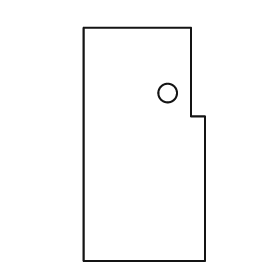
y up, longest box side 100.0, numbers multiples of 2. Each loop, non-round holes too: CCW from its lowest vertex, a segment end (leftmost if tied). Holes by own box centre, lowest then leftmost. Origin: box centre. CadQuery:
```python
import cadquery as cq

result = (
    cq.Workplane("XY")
    .moveTo(-26.0, -50.0)
    .lineTo(26.0, -50.0)
    .lineTo(26.0, 12.0)
    .lineTo(20.0, 12.0)
    .lineTo(20.0, 50.0)
    .lineTo(-26.0, 50.0)
    .close()
    .moveTo(10.0, 22.0)
    .circle(4.0)
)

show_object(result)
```